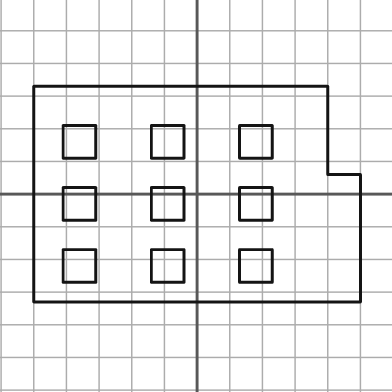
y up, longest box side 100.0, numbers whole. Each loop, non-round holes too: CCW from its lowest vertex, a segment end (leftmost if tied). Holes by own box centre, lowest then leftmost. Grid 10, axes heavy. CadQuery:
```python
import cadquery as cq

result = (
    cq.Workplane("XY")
    .moveTo(-50.0, -33.0)
    .lineTo(50.0, -33.0)
    .lineTo(50.0, 6.0)
    .lineTo(40.0, 6.0)
    .lineTo(40.0, 33.0)
    .lineTo(-50.0, 33.0)
    .close()
    .moveTo(-41.0, -27.0)
    .lineTo(-31.0, -27.0)
    .lineTo(-31.0, -17.0)
    .lineTo(-41.0, -17.0)
    .close()
    .moveTo(-14.0, -27.0)
    .lineTo(-4.0, -27.0)
    .lineTo(-4.0, -17.0)
    .lineTo(-14.0, -17.0)
    .close()
    .moveTo(13.0, -27.0)
    .lineTo(23.0, -27.0)
    .lineTo(23.0, -17.0)
    .lineTo(13.0, -17.0)
    .close()
    .moveTo(-41.0, -8.0)
    .lineTo(-31.0, -8.0)
    .lineTo(-31.0, 2.0)
    .lineTo(-41.0, 2.0)
    .close()
    .moveTo(-14.0, -8.0)
    .lineTo(-4.0, -8.0)
    .lineTo(-4.0, 2.0)
    .lineTo(-14.0, 2.0)
    .close()
    .moveTo(13.0, -8.0)
    .lineTo(23.0, -8.0)
    .lineTo(23.0, 2.0)
    .lineTo(13.0, 2.0)
    .close()
    .moveTo(-41.0, 11.0)
    .lineTo(-31.0, 11.0)
    .lineTo(-31.0, 21.0)
    .lineTo(-41.0, 21.0)
    .close()
    .moveTo(-14.0, 11.0)
    .lineTo(-4.0, 11.0)
    .lineTo(-4.0, 21.0)
    .lineTo(-14.0, 21.0)
    .close()
    .moveTo(13.0, 11.0)
    .lineTo(23.0, 11.0)
    .lineTo(23.0, 21.0)
    .lineTo(13.0, 21.0)
    .close()
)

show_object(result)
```